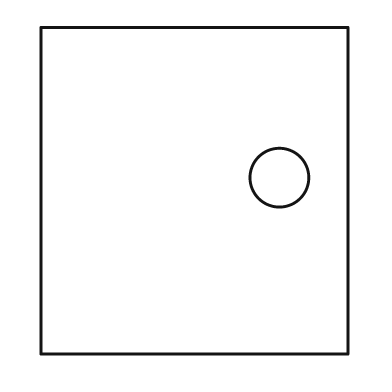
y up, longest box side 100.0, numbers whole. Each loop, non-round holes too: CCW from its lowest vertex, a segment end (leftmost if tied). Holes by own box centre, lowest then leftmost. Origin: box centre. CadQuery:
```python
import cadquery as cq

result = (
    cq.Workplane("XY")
    .moveTo(-47.0, -50.0)
    .lineTo(47.0, -50.0)
    .lineTo(47.0, 50.0)
    .lineTo(-47.0, 50.0)
    .close()
    .moveTo(26.0, 4.0)
    .circle(9.0)
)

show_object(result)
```